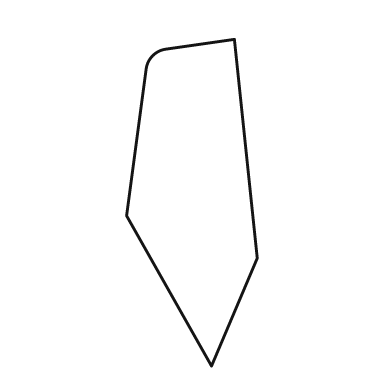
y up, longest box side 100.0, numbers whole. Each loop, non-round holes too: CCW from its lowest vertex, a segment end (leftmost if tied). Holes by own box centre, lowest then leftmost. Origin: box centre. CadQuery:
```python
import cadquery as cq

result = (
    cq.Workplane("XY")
    .moveTo(6.0, -50.0)
    .lineTo(20.0, -17.0)
    .lineTo(13.0, 50.0)
    .lineTo(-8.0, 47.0)
    .threePointArc((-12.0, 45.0), (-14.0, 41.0))
    .lineTo(-20.0, -4.0)
    .close()
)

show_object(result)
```